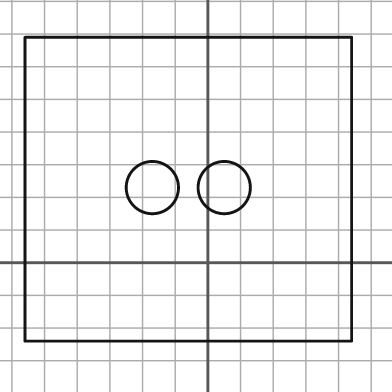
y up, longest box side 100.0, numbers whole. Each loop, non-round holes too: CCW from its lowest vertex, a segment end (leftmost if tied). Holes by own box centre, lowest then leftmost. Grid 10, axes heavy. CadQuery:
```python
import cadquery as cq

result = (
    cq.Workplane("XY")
    .moveTo(-56.0, -24.0)
    .lineTo(44.0, -24.0)
    .lineTo(44.0, 69.0)
    .lineTo(-56.0, 69.0)
    .close()
    .moveTo(-17.0, 23.0)
    .circle(8.0)
    .moveTo(5.0, 23.0)
    .circle(8.0)
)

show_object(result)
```